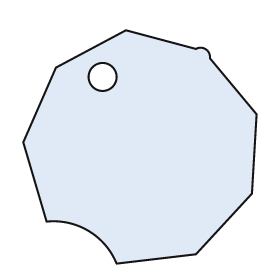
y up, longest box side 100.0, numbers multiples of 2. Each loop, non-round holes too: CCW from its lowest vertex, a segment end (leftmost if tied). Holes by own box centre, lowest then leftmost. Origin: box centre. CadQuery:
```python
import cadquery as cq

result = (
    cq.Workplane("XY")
    .moveTo(-10.0, -50.0)
    .lineTo(24.0, -46.0)
    .lineTo(48.0, -20.0)
    .lineTo(50.0, 14.0)
    .lineTo(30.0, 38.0)
    .threePointArc((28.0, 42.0), (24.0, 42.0))
    .lineTo(-6.0, 50.0)
    .lineTo(-36.0, 34.0)
    .lineTo(-50.0, 2.0)
    .lineTo(-40.0, -32.0)
    .threePointArc((-22.0, -36.0), (-10.0, -50.0))
    .close()
    .moveTo(-16.0, 30.0)
    .circle(6.0)
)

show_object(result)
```